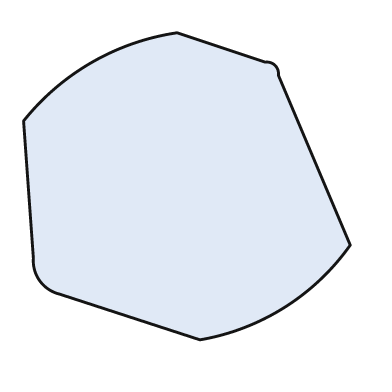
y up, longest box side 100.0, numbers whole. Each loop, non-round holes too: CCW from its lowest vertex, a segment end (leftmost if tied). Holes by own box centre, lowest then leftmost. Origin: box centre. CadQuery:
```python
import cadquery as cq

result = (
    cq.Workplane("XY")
    .moveTo(4.0, -47.0)
    .threePointArc((30.0, -37.0), (50.0, -18.0))
    .lineTo(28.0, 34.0)
    .threePointArc((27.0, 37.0), (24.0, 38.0))
    .lineTo(-3.0, 47.0)
    .threePointArc((-29.0, 38.0), (-50.0, 20.0))
    .lineTo(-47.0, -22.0)
    .threePointArc((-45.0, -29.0), (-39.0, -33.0))
    .close()
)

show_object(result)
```